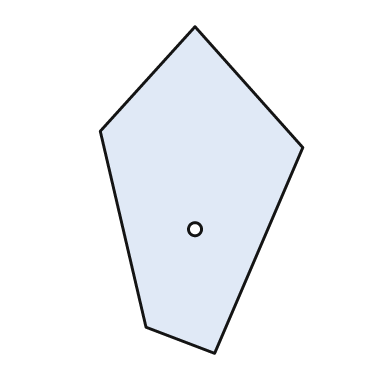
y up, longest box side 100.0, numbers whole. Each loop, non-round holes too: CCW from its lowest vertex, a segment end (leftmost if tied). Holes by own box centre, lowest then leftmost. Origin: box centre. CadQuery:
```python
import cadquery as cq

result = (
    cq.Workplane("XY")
    .moveTo(4.0, -50.0)
    .lineTo(31.0, 13.0)
    .lineTo(-2.0, 50.0)
    .lineTo(-31.0, 18.0)
    .lineTo(-17.0, -42.0)
    .close()
    .moveTo(-2.0, -12.0)
    .circle(2.0)
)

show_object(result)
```